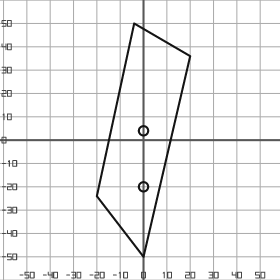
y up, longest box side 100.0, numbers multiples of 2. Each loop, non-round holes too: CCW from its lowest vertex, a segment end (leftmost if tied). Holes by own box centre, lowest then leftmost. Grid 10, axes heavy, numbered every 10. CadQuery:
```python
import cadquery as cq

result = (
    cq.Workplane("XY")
    .moveTo(0.0, -50.0)
    .lineTo(20.0, 36.0)
    .lineTo(-4.0, 50.0)
    .lineTo(-20.0, -24.0)
    .close()
    .moveTo(0.0, -20.0)
    .circle(2.0)
    .moveTo(0.0, 4.0)
    .circle(2.0)
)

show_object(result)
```